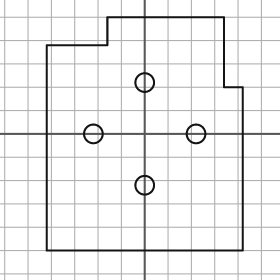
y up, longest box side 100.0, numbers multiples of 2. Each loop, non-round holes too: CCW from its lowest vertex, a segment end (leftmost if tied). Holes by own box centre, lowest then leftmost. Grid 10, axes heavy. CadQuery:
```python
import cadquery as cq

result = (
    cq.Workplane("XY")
    .moveTo(-42.0, -50.0)
    .lineTo(42.0, -50.0)
    .lineTo(42.0, 20.0)
    .lineTo(34.0, 20.0)
    .lineTo(34.0, 50.0)
    .lineTo(-16.0, 50.0)
    .lineTo(-16.0, 38.0)
    .lineTo(-42.0, 38.0)
    .close()
    .moveTo(0.0, -22.0)
    .circle(4.0)
    .moveTo(-22.0, 0.0)
    .circle(4.0)
    .moveTo(22.0, 0.0)
    .circle(4.0)
    .moveTo(0.0, 22.0)
    .circle(4.0)
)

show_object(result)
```